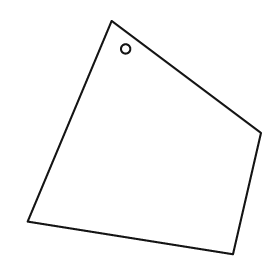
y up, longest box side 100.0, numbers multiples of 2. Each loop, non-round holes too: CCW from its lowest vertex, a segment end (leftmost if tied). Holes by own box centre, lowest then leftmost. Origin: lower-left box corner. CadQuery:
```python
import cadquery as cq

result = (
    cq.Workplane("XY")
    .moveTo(88.0, 0.0)
    .lineTo(100.0, 52.0)
    .lineTo(36.0, 100.0)
    .lineTo(0.0, 14.0)
    .close()
    .moveTo(42.0, 88.0)
    .circle(2.0)
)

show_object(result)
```